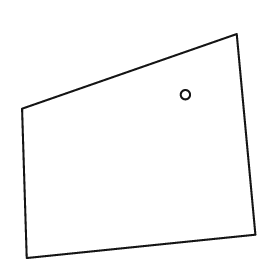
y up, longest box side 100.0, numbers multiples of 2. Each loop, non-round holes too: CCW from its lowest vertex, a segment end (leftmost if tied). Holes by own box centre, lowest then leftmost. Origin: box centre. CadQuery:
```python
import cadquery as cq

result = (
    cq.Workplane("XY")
    .moveTo(-48.0, -48.0)
    .lineTo(50.0, -38.0)
    .lineTo(42.0, 48.0)
    .lineTo(-50.0, 16.0)
    .close()
    .moveTo(20.0, 22.0)
    .circle(2.0)
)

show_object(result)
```